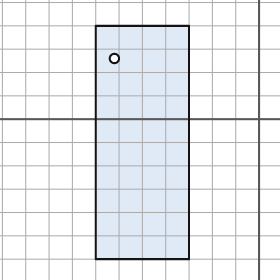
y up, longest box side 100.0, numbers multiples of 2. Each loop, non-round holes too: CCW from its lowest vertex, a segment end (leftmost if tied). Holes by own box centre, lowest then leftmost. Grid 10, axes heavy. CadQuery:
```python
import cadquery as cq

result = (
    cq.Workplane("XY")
    .moveTo(-70.0, -60.0)
    .lineTo(-30.0, -60.0)
    .lineTo(-30.0, 40.0)
    .lineTo(-70.0, 40.0)
    .close()
    .moveTo(-62.0, 26.0)
    .circle(2.0)
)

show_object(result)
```